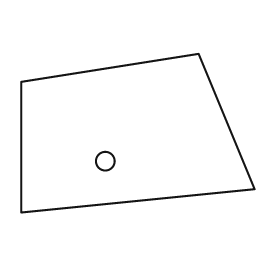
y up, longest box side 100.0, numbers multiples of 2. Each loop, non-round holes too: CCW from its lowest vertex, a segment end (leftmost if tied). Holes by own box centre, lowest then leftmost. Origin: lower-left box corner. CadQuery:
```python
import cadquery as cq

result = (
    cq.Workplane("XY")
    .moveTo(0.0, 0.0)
    .lineTo(100.0, 10.0)
    .lineTo(76.0, 68.0)
    .lineTo(0.0, 56.0)
    .close()
    .moveTo(36.0, 22.0)
    .circle(4.0)
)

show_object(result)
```